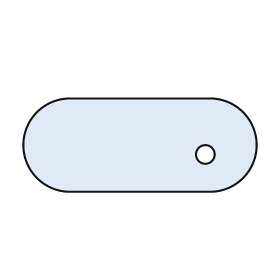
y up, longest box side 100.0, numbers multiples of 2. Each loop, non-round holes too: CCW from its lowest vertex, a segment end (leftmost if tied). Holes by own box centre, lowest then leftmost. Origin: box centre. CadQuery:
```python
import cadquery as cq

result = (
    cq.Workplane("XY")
    .moveTo(-30.0, -20.0)
    .lineTo(30.0, -20.0)
    .threePointArc((50.0, 0.0), (30.0, 20.0))
    .lineTo(-30.0, 20.0)
    .threePointArc((-50.0, 0.0), (-30.0, -20.0))
    .close()
    .moveTo(28.0, -4.0)
    .circle(4.0)
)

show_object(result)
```